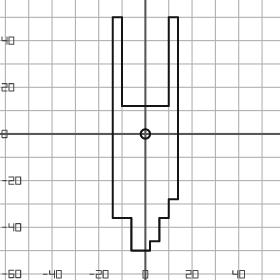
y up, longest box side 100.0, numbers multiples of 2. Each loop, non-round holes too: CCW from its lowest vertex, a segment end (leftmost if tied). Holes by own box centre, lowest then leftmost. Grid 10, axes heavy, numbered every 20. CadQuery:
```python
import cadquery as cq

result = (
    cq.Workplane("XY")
    .moveTo(-6.0, -50.0)
    .lineTo(2.0, -50.0)
    .lineTo(2.0, -46.0)
    .lineTo(6.0, -46.0)
    .lineTo(6.0, -36.0)
    .lineTo(10.0, -36.0)
    .lineTo(10.0, -28.0)
    .lineTo(14.0, -28.0)
    .lineTo(14.0, 50.0)
    .lineTo(10.0, 50.0)
    .lineTo(10.0, 12.0)
    .lineTo(-10.0, 12.0)
    .lineTo(-10.0, 50.0)
    .lineTo(-14.0, 50.0)
    .lineTo(-14.0, -36.0)
    .lineTo(-6.0, -36.0)
    .close()
    .moveTo(0.0, 0.0)
    .circle(2.0)
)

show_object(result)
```